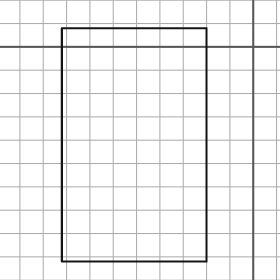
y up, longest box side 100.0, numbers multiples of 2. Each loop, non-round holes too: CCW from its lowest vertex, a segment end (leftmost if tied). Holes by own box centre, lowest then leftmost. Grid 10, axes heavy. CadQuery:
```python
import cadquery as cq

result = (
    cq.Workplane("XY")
    .moveTo(-82.0, -92.0)
    .lineTo(-20.0, -92.0)
    .lineTo(-20.0, 8.0)
    .lineTo(-82.0, 8.0)
    .close()
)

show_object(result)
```